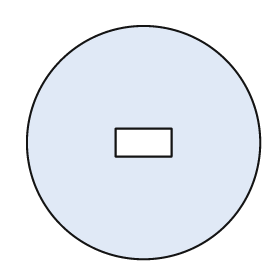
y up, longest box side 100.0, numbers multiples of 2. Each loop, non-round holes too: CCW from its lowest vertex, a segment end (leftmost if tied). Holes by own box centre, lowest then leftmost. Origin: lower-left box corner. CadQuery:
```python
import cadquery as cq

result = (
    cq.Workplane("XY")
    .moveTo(50.0, 50.0)
    .circle(50.0)
    .moveTo(38.0, 44.0)
    .lineTo(62.0, 44.0)
    .lineTo(62.0, 56.0)
    .lineTo(38.0, 56.0)
    .close()
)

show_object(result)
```